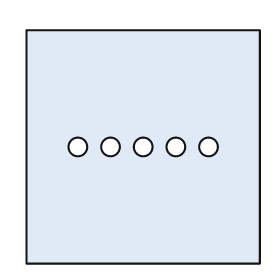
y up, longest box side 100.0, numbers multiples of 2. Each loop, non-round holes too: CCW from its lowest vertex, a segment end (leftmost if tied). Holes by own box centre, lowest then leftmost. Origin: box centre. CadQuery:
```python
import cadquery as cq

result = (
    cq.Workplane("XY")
    .moveTo(-50.0, -50.0)
    .lineTo(50.0, -50.0)
    .lineTo(50.0, 50.0)
    .lineTo(-50.0, 50.0)
    .close()
    .moveTo(-28.0, 0.0)
    .circle(4.0)
    .moveTo(-14.0, 0.0)
    .circle(4.0)
    .moveTo(0.0, 0.0)
    .circle(4.0)
    .moveTo(14.0, 0.0)
    .circle(4.0)
    .moveTo(28.0, 0.0)
    .circle(4.0)
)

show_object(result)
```